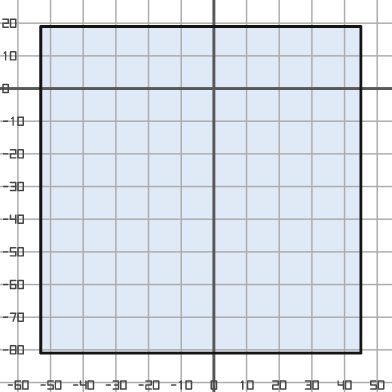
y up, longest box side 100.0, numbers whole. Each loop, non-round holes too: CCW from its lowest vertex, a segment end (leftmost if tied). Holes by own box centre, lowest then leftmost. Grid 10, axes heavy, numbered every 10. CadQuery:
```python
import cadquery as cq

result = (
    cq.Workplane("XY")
    .moveTo(-53.0, -81.0)
    .lineTo(45.0, -81.0)
    .lineTo(45.0, 19.0)
    .lineTo(-53.0, 19.0)
    .close()
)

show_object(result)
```